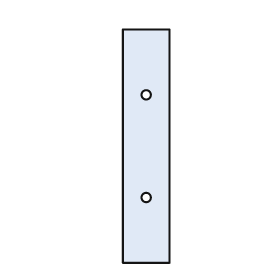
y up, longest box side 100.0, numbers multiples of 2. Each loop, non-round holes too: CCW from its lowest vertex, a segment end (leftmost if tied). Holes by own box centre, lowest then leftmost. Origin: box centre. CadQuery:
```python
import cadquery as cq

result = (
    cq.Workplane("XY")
    .moveTo(-10.0, -50.0)
    .lineTo(10.0, -50.0)
    .lineTo(10.0, 50.0)
    .lineTo(-10.0, 50.0)
    .close()
    .moveTo(0.0, -22.0)
    .circle(2.0)
    .moveTo(0.0, 22.0)
    .circle(2.0)
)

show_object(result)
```